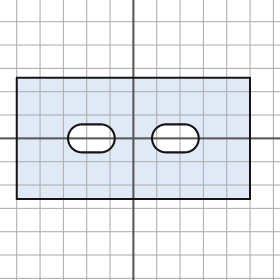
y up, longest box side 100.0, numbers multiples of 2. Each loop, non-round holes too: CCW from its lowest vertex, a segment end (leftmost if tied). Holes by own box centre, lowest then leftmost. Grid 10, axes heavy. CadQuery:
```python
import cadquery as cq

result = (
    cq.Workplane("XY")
    .moveTo(-50.0, -26.0)
    .lineTo(50.0, -26.0)
    .lineTo(50.0, 26.0)
    .lineTo(-50.0, 26.0)
    .close()
    .moveTo(-22.0, -6.0)
    .lineTo(-14.0, -6.0)
    .threePointArc((-8.0, 0.0), (-14.0, 6.0))
    .lineTo(-22.0, 6.0)
    .threePointArc((-28.0, 0.0), (-22.0, -6.0))
    .close()
    .moveTo(14.0, -6.0)
    .lineTo(22.0, -6.0)
    .threePointArc((28.0, 0.0), (22.0, 6.0))
    .lineTo(14.0, 6.0)
    .threePointArc((8.0, 0.0), (14.0, -6.0))
    .close()
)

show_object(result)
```